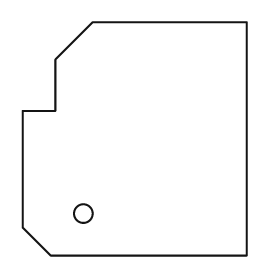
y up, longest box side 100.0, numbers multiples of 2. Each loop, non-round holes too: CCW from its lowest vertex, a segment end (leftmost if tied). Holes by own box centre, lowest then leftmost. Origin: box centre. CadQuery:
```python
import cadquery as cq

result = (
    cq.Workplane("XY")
    .moveTo(-36.0, -50.0)
    .lineTo(48.0, -50.0)
    .lineTo(48.0, 50.0)
    .lineTo(-18.0, 50.0)
    .lineTo(-34.0, 34.0)
    .lineTo(-34.0, 12.0)
    .lineTo(-48.0, 12.0)
    .lineTo(-48.0, -38.0)
    .close()
    .moveTo(-22.0, -32.0)
    .circle(4.0)
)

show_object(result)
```